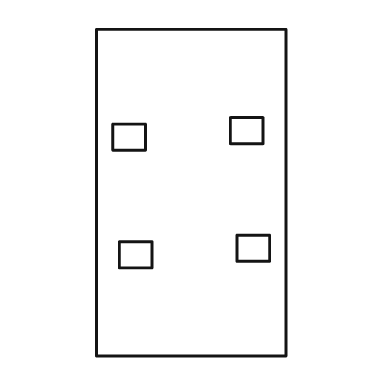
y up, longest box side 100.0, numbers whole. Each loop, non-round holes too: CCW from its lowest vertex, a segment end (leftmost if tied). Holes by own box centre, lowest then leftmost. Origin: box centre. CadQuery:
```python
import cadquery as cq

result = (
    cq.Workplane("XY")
    .moveTo(-29.0, -50.0)
    .lineTo(29.0, -50.0)
    .lineTo(29.0, 50.0)
    .lineTo(-29.0, 50.0)
    .close()
    .moveTo(-22.0, -23.0)
    .lineTo(-12.0, -23.0)
    .lineTo(-12.0, -15.0)
    .lineTo(-22.0, -15.0)
    .close()
    .moveTo(14.0, -21.0)
    .lineTo(24.0, -21.0)
    .lineTo(24.0, -13.0)
    .lineTo(14.0, -13.0)
    .close()
    .moveTo(-24.0, 13.0)
    .lineTo(-14.0, 13.0)
    .lineTo(-14.0, 21.0)
    .lineTo(-24.0, 21.0)
    .close()
    .moveTo(12.0, 15.0)
    .lineTo(22.0, 15.0)
    .lineTo(22.0, 23.0)
    .lineTo(12.0, 23.0)
    .close()
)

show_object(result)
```